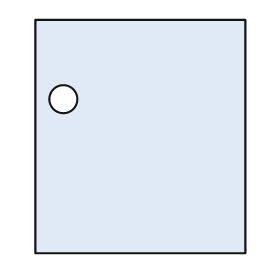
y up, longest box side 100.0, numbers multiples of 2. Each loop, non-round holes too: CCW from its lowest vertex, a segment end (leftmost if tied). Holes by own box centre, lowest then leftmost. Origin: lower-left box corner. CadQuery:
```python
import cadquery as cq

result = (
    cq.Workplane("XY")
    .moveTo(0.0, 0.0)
    .lineTo(90.0, 0.0)
    .lineTo(90.0, 100.0)
    .lineTo(0.0, 100.0)
    .close()
    .moveTo(12.0, 66.0)
    .circle(6.0)
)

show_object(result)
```